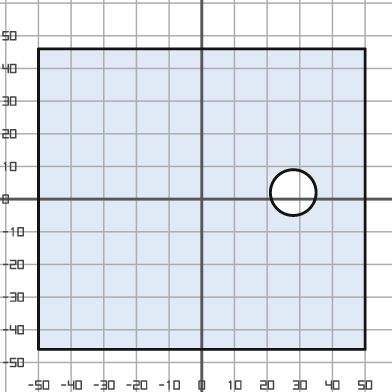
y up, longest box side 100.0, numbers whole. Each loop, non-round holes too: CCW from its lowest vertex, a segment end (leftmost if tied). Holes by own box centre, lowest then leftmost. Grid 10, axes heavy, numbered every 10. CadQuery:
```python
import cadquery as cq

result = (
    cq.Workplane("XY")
    .moveTo(-50.0, -46.0)
    .lineTo(50.0, -46.0)
    .lineTo(50.0, 46.0)
    .lineTo(-50.0, 46.0)
    .close()
    .moveTo(28.0, 2.0)
    .circle(7.0)
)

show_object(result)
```